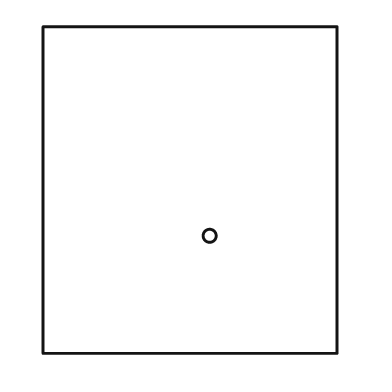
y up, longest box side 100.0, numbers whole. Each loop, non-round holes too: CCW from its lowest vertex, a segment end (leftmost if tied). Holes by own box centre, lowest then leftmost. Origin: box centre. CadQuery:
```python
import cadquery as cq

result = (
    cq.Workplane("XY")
    .moveTo(-45.0, -50.0)
    .lineTo(45.0, -50.0)
    .lineTo(45.0, 50.0)
    .lineTo(-45.0, 50.0)
    .close()
    .moveTo(6.0, -14.0)
    .circle(2.0)
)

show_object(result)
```